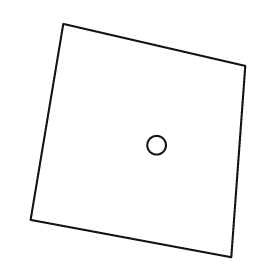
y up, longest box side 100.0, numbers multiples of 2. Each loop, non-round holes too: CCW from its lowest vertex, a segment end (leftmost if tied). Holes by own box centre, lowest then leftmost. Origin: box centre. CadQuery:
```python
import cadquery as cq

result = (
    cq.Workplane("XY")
    .moveTo(40.0, -50.0)
    .lineTo(46.0, 32.0)
    .lineTo(-32.0, 50.0)
    .lineTo(-46.0, -34.0)
    .close()
    .moveTo(8.0, -2.0)
    .circle(4.0)
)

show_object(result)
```